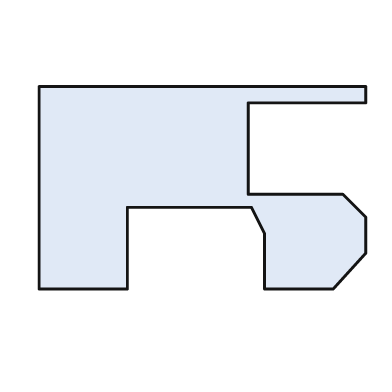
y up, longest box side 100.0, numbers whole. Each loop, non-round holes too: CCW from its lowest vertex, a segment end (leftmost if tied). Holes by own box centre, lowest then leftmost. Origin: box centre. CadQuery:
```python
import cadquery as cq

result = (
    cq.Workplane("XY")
    .moveTo(-50.0, -31.0)
    .lineTo(-23.0, -31.0)
    .lineTo(-23.0, -6.0)
    .lineTo(15.0, -6.0)
    .lineTo(19.0, -14.0)
    .lineTo(19.0, -31.0)
    .lineTo(40.0, -31.0)
    .lineTo(50.0, -20.0)
    .lineTo(50.0, -9.0)
    .lineTo(43.0, -2.0)
    .lineTo(14.0, -2.0)
    .lineTo(14.0, 26.0)
    .lineTo(50.0, 26.0)
    .lineTo(50.0, 31.0)
    .lineTo(-50.0, 31.0)
    .close()
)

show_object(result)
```